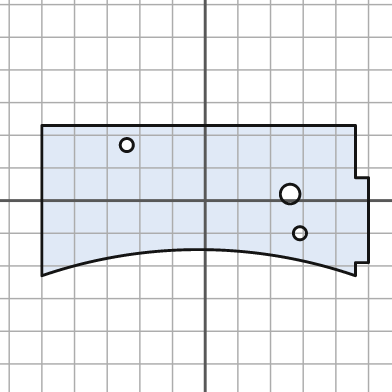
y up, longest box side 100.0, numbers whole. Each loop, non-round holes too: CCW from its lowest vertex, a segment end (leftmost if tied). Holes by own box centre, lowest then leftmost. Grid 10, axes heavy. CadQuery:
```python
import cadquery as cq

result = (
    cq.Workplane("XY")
    .moveTo(-50.0, -23.0)
    .threePointArc((-2.0, -15.0), (46.0, -23.0))
    .lineTo(46.0, -19.0)
    .lineTo(50.0, -19.0)
    .lineTo(50.0, 7.0)
    .lineTo(46.0, 7.0)
    .lineTo(46.0, 23.0)
    .lineTo(-50.0, 23.0)
    .close()
    .moveTo(29.0, -10.0)
    .circle(2.0)
    .moveTo(26.0, 2.0)
    .circle(3.0)
    .moveTo(-24.0, 17.0)
    .circle(2.0)
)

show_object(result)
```